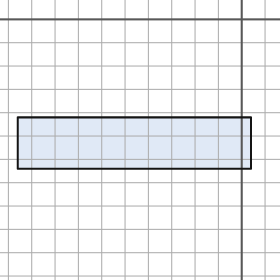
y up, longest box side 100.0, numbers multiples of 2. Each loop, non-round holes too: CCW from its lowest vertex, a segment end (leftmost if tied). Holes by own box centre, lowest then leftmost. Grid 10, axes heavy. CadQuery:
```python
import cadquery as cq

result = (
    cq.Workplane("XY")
    .moveTo(-96.0, -64.0)
    .lineTo(4.0, -64.0)
    .lineTo(4.0, -42.0)
    .lineTo(-96.0, -42.0)
    .close()
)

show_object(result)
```